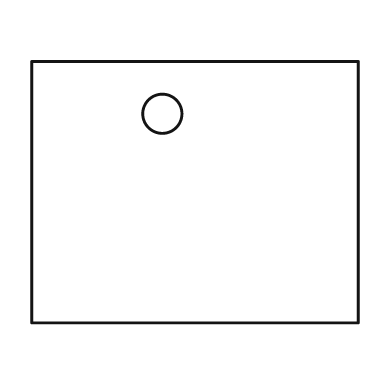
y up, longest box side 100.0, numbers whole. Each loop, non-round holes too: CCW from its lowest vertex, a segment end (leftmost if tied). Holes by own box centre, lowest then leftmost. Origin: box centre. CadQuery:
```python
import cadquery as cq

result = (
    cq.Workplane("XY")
    .moveTo(-50.0, -40.0)
    .lineTo(50.0, -40.0)
    .lineTo(50.0, 40.0)
    .lineTo(-50.0, 40.0)
    .close()
    .moveTo(-10.0, 24.0)
    .circle(6.0)
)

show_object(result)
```